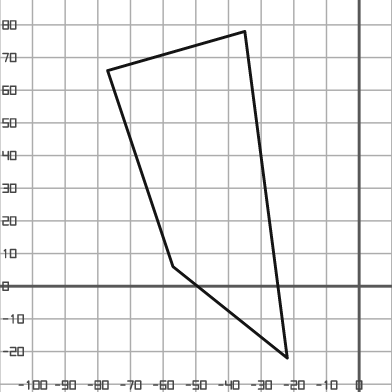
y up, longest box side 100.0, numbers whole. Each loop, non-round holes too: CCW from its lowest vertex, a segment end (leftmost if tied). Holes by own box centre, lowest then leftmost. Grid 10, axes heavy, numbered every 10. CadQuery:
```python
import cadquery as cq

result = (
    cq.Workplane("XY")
    .moveTo(-22.0, -22.0)
    .lineTo(-35.0, 78.0)
    .lineTo(-77.0, 66.0)
    .lineTo(-57.0, 6.0)
    .close()
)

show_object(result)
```